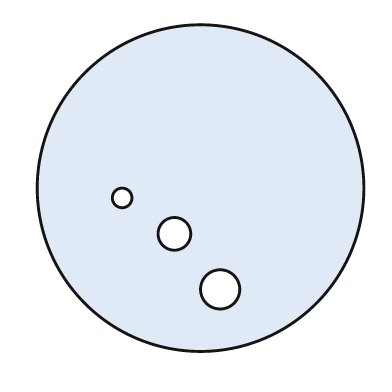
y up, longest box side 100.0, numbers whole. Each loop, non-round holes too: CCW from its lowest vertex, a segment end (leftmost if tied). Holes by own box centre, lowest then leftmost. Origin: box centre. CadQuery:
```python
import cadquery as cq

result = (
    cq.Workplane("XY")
    .moveTo(0.0, 0.0)
    .circle(50.0)
    .moveTo(6.0, -31.0)
    .circle(6.0)
    .moveTo(-8.0, -14.0)
    .circle(5.0)
    .moveTo(-24.0, -3.0)
    .circle(3.0)
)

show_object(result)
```